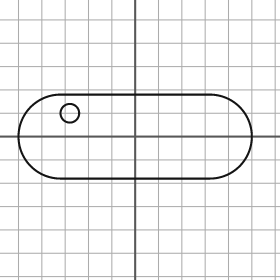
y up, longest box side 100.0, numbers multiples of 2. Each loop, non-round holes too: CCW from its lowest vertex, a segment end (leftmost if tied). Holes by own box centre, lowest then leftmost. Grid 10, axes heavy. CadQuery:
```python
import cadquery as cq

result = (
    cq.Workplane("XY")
    .moveTo(-32.0, -18.0)
    .lineTo(32.0, -18.0)
    .threePointArc((50.0, 0.0), (32.0, 18.0))
    .lineTo(-32.0, 18.0)
    .threePointArc((-50.0, 0.0), (-32.0, -18.0))
    .close()
    .moveTo(-28.0, 10.0)
    .circle(4.0)
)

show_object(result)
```